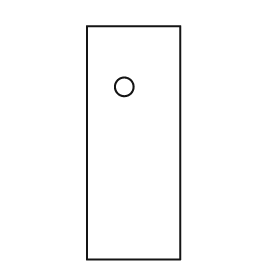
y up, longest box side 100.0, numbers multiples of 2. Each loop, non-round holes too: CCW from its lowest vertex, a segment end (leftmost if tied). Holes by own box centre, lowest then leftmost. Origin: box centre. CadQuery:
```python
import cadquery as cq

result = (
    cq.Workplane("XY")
    .moveTo(-20.0, -50.0)
    .lineTo(20.0, -50.0)
    .lineTo(20.0, 50.0)
    .lineTo(-20.0, 50.0)
    .close()
    .moveTo(-4.0, 24.0)
    .circle(4.0)
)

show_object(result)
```